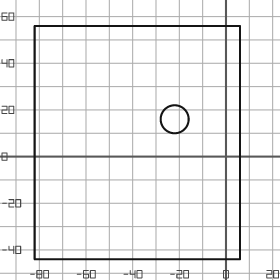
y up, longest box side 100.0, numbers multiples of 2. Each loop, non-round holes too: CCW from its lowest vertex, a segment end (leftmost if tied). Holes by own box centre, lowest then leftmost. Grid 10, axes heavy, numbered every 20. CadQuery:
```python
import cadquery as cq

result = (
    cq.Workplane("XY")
    .moveTo(-82.0, -44.0)
    .lineTo(6.0, -44.0)
    .lineTo(6.0, 56.0)
    .lineTo(-82.0, 56.0)
    .close()
    .moveTo(-22.0, 16.0)
    .circle(6.0)
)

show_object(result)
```